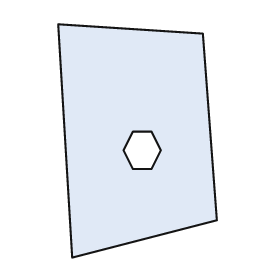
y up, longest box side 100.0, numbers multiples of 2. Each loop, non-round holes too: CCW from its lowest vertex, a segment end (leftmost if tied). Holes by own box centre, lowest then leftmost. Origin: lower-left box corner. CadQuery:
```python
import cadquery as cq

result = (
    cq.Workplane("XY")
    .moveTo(6.0, 0.0)
    .lineTo(68.0, 16.0)
    .lineTo(62.0, 96.0)
    .lineTo(0.0, 100.0)
    .close()
    .moveTo(32.0, 38.0)
    .lineTo(40.0, 38.0)
    .lineTo(44.0, 46.0)
    .lineTo(40.0, 54.0)
    .lineTo(32.0, 54.0)
    .lineTo(28.0, 46.0)
    .close()
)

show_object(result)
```